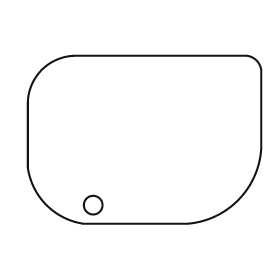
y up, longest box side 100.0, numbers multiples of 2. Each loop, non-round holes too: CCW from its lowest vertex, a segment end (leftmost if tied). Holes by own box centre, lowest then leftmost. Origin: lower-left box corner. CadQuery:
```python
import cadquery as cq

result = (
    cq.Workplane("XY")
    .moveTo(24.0, 0.0)
    .lineTo(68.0, 0.0)
    .threePointArc((90.0, 10.0), (100.0, 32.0))
    .lineTo(100.0, 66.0)
    .threePointArc((98.0, 70.0), (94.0, 72.0))
    .lineTo(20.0, 72.0)
    .threePointArc((6.0, 66.0), (0.0, 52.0))
    .lineTo(0.0, 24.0)
    .threePointArc((8.0, 8.0), (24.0, 0.0))
    .close()
    .moveTo(28.0, 8.0)
    .circle(4.0)
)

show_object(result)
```